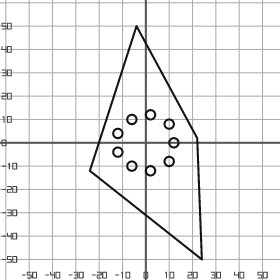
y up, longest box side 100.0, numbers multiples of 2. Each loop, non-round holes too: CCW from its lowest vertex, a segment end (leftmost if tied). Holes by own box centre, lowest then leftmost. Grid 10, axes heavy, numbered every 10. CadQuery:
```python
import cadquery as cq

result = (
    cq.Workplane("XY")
    .moveTo(24.0, -50.0)
    .lineTo(22.0, 2.0)
    .lineTo(-4.0, 50.0)
    .lineTo(-24.0, -12.0)
    .close()
    .moveTo(2.0, -12.0)
    .circle(2.0)
    .moveTo(-6.0, -10.0)
    .circle(2.0)
    .moveTo(10.0, -8.0)
    .circle(2.0)
    .moveTo(-12.0, -4.0)
    .circle(2.0)
    .moveTo(12.0, 0.0)
    .circle(2.0)
    .moveTo(-12.0, 4.0)
    .circle(2.0)
    .moveTo(10.0, 8.0)
    .circle(2.0)
    .moveTo(-6.0, 10.0)
    .circle(2.0)
    .moveTo(2.0, 12.0)
    .circle(2.0)
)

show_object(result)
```